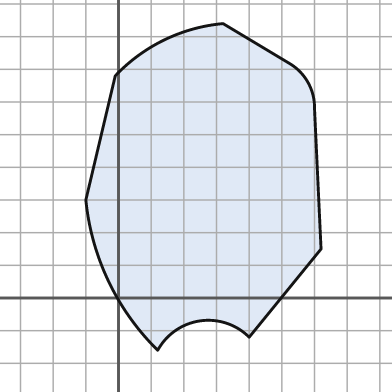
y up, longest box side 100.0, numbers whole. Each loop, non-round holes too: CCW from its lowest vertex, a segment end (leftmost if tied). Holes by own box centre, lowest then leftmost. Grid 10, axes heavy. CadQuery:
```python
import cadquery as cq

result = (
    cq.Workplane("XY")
    .moveTo(12.0, -16.0)
    .threePointArc((25.0, -7.0), (40.0, -12.0))
    .lineTo(62.0, 15.0)
    .lineTo(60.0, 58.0)
    .threePointArc((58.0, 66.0), (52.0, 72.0))
    .lineTo(32.0, 84.0)
    .threePointArc((14.0, 79.0), (-1.0, 68.0))
    .lineTo(-10.0, 30.0)
    .threePointArc((-3.0, 5.0), (12.0, -16.0))
    .close()
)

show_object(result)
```